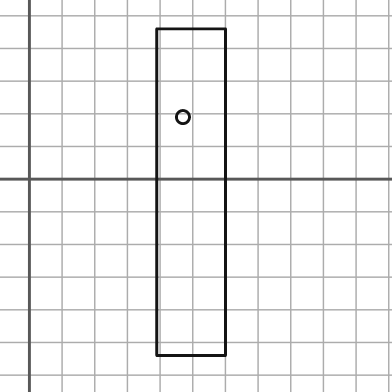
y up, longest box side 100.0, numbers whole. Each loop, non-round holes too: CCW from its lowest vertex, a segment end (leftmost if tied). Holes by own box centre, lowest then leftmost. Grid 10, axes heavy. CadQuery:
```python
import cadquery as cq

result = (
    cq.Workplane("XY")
    .moveTo(39.0, -54.0)
    .lineTo(60.0, -54.0)
    .lineTo(60.0, 46.0)
    .lineTo(39.0, 46.0)
    .close()
    .moveTo(47.0, 19.0)
    .circle(2.0)
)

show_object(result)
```